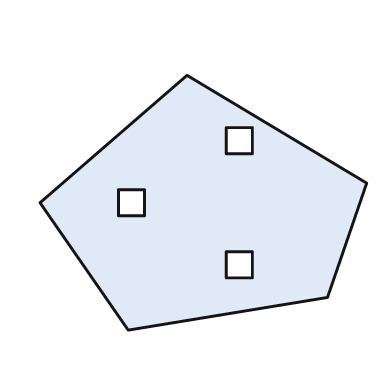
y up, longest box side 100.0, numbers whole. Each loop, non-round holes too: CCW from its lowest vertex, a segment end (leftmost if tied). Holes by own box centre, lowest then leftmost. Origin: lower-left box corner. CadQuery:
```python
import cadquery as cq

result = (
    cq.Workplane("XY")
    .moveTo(27.0, 0.0)
    .lineTo(88.0, 10.0)
    .lineTo(100.0, 45.0)
    .lineTo(45.0, 78.0)
    .lineTo(0.0, 39.0)
    .close()
    .moveTo(57.0, 16.0)
    .lineTo(65.0, 16.0)
    .lineTo(65.0, 24.0)
    .lineTo(57.0, 24.0)
    .close()
    .moveTo(24.0, 35.0)
    .lineTo(32.0, 35.0)
    .lineTo(32.0, 43.0)
    .lineTo(24.0, 43.0)
    .close()
    .moveTo(57.0, 54.0)
    .lineTo(65.0, 54.0)
    .lineTo(65.0, 62.0)
    .lineTo(57.0, 62.0)
    .close()
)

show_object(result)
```